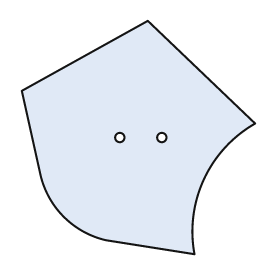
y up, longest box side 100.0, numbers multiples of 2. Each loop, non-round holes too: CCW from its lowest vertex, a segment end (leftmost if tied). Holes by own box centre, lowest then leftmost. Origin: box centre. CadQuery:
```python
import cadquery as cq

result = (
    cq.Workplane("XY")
    .moveTo(24.0, -50.0)
    .threePointArc((28.0, -18.0), (50.0, 6.0))
    .lineTo(4.0, 50.0)
    .lineTo(-50.0, 20.0)
    .lineTo(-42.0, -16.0)
    .threePointArc((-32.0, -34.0), (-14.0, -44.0))
    .close()
    .moveTo(-8.0, 0.0)
    .circle(2.0)
    .moveTo(10.0, 0.0)
    .circle(2.0)
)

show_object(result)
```